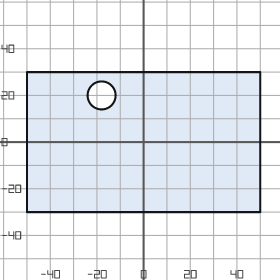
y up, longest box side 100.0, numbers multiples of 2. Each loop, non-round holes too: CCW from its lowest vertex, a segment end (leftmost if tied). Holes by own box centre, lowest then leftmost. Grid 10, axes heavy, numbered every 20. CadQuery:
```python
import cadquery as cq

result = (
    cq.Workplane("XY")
    .moveTo(-50.0, -30.0)
    .lineTo(50.0, -30.0)
    .lineTo(50.0, 30.0)
    .lineTo(-50.0, 30.0)
    .close()
    .moveTo(-18.0, 20.0)
    .circle(6.0)
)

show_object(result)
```